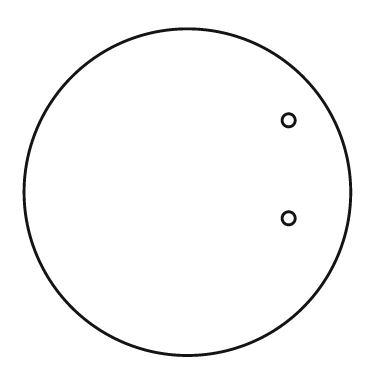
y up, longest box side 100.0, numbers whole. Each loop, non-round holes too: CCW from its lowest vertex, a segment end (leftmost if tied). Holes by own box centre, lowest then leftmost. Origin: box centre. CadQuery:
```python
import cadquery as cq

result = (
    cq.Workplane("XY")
    .moveTo(0.0, 0.0)
    .circle(50.0)
    .moveTo(31.0, -8.0)
    .circle(2.0)
    .moveTo(31.0, 22.0)
    .circle(2.0)
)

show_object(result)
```